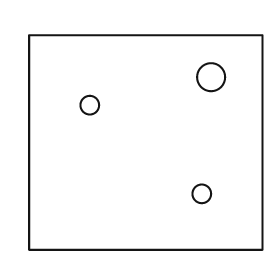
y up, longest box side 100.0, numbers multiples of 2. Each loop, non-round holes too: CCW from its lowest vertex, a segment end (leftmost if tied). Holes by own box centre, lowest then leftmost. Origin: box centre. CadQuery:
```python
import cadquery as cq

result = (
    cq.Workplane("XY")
    .moveTo(-50.0, -46.0)
    .lineTo(50.0, -46.0)
    .lineTo(50.0, 46.0)
    .lineTo(-50.0, 46.0)
    .close()
    .moveTo(24.0, -22.0)
    .circle(4.0)
    .moveTo(-24.0, 16.0)
    .circle(4.0)
    .moveTo(28.0, 28.0)
    .circle(6.0)
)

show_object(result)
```